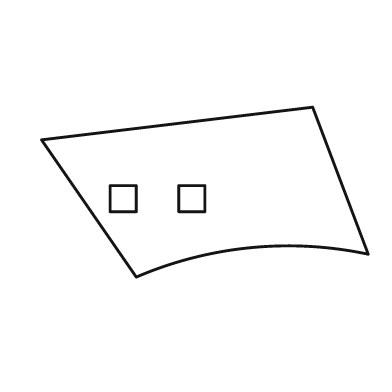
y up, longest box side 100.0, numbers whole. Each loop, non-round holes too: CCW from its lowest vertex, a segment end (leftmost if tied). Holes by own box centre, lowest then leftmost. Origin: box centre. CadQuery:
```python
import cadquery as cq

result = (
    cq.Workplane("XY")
    .moveTo(-21.0, -26.0)
    .threePointArc((14.0, -17.0), (50.0, -19.0))
    .lineTo(33.0, 26.0)
    .lineTo(-50.0, 16.0)
    .close()
    .moveTo(-29.0, -6.0)
    .lineTo(-21.0, -6.0)
    .lineTo(-21.0, 2.0)
    .lineTo(-29.0, 2.0)
    .close()
    .moveTo(-8.0, -6.0)
    .lineTo(0.0, -6.0)
    .lineTo(0.0, 2.0)
    .lineTo(-8.0, 2.0)
    .close()
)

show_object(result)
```